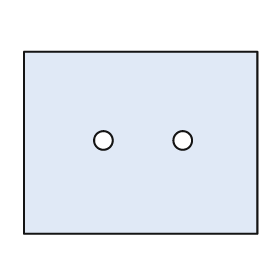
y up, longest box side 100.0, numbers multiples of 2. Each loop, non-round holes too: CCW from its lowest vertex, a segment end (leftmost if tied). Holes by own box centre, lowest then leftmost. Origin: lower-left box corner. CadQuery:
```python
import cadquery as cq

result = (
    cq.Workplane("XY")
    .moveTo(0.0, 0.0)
    .lineTo(100.0, 0.0)
    .lineTo(100.0, 78.0)
    .lineTo(0.0, 78.0)
    .close()
    .moveTo(34.0, 40.0)
    .circle(4.0)
    .moveTo(68.0, 40.0)
    .circle(4.0)
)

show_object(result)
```